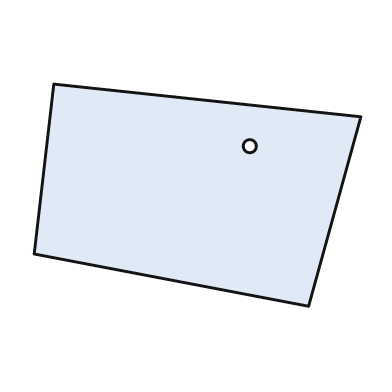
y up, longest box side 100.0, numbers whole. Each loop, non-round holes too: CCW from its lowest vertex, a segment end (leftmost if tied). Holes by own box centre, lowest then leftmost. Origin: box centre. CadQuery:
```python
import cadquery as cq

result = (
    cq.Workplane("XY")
    .moveTo(34.0, -34.0)
    .lineTo(50.0, 24.0)
    .lineTo(-44.0, 34.0)
    .lineTo(-50.0, -18.0)
    .close()
    .moveTo(16.0, 15.0)
    .circle(2.0)
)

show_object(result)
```